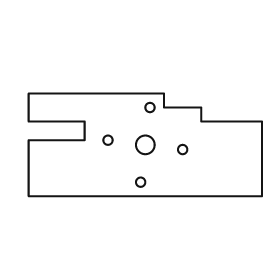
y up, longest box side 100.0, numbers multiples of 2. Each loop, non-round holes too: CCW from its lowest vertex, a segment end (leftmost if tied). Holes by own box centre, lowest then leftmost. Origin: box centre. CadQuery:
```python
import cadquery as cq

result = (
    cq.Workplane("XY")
    .moveTo(-50.0, -22.0)
    .lineTo(50.0, -22.0)
    .lineTo(50.0, 10.0)
    .lineTo(24.0, 10.0)
    .lineTo(24.0, 16.0)
    .lineTo(8.0, 16.0)
    .lineTo(8.0, 22.0)
    .lineTo(-50.0, 22.0)
    .lineTo(-50.0, 10.0)
    .lineTo(-26.0, 10.0)
    .lineTo(-26.0, 2.0)
    .lineTo(-50.0, 2.0)
    .close()
    .moveTo(-2.0, -16.0)
    .circle(2.0)
    .moveTo(16.0, -2.0)
    .circle(2.0)
    .moveTo(0.0, 0.0)
    .circle(4.0)
    .moveTo(-16.0, 2.0)
    .circle(2.0)
    .moveTo(2.0, 16.0)
    .circle(2.0)
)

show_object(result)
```